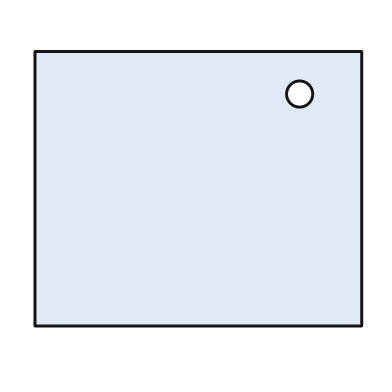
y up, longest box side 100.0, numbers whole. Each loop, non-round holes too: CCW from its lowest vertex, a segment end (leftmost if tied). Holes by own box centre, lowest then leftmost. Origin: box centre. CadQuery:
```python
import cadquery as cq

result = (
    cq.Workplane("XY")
    .moveTo(-50.0, -42.0)
    .lineTo(50.0, -42.0)
    .lineTo(50.0, 42.0)
    .lineTo(-50.0, 42.0)
    .close()
    .moveTo(31.0, 29.0)
    .circle(4.0)
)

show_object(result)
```